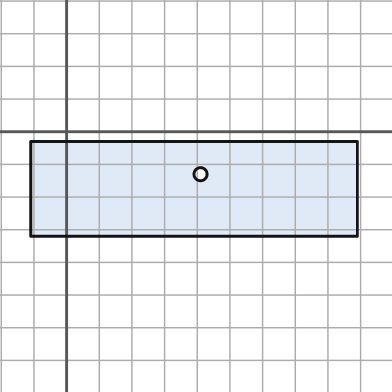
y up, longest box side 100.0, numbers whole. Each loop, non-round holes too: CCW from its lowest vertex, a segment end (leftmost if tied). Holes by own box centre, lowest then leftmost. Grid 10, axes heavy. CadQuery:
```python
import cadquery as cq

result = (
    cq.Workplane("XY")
    .moveTo(-11.0, -32.0)
    .lineTo(89.0, -32.0)
    .lineTo(89.0, -3.0)
    .lineTo(-11.0, -3.0)
    .close()
    .moveTo(41.0, -13.0)
    .circle(2.0)
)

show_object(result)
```